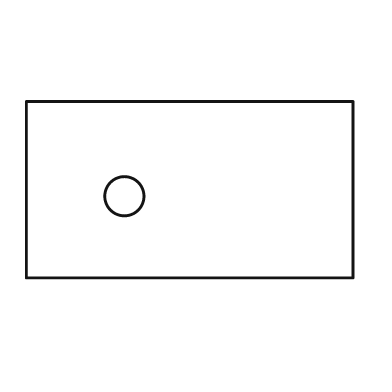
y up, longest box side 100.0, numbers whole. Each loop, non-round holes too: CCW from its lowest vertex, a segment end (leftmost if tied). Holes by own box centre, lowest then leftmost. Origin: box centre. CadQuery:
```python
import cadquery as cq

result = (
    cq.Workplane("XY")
    .moveTo(-50.0, -27.0)
    .lineTo(50.0, -27.0)
    .lineTo(50.0, 27.0)
    .lineTo(-50.0, 27.0)
    .close()
    .moveTo(-20.0, -2.0)
    .circle(6.0)
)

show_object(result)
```